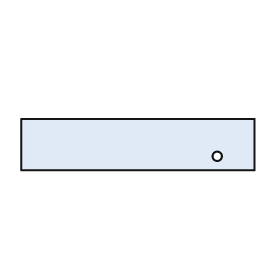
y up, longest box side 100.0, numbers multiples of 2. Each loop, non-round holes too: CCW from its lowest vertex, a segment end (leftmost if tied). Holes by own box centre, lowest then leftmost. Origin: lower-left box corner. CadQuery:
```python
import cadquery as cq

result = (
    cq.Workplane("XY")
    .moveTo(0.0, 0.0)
    .lineTo(100.0, 0.0)
    .lineTo(100.0, 22.0)
    .lineTo(0.0, 22.0)
    .close()
    .moveTo(84.0, 6.0)
    .circle(2.0)
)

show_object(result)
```